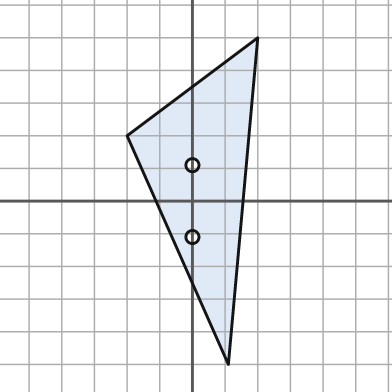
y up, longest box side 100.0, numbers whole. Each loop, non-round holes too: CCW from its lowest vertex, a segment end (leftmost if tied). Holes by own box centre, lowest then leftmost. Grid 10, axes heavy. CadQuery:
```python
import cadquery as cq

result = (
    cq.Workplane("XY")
    .moveTo(11.0, -50.0)
    .lineTo(20.0, 50.0)
    .lineTo(-20.0, 20.0)
    .close()
    .moveTo(0.0, -11.0)
    .circle(2.0)
    .moveTo(0.0, 11.0)
    .circle(2.0)
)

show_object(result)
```